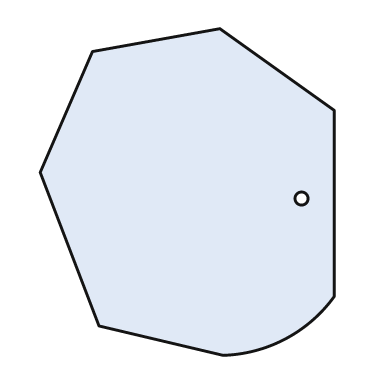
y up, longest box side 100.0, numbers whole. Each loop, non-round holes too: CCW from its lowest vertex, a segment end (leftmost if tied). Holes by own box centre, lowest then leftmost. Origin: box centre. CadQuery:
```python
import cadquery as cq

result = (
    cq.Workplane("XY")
    .moveTo(11.0, -50.0)
    .threePointArc((30.0, -45.0), (45.0, -32.0))
    .lineTo(45.0, 25.0)
    .lineTo(10.0, 50.0)
    .lineTo(-29.0, 43.0)
    .lineTo(-45.0, 6.0)
    .lineTo(-27.0, -41.0)
    .close()
    .moveTo(35.0, -2.0)
    .circle(2.0)
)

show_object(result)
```